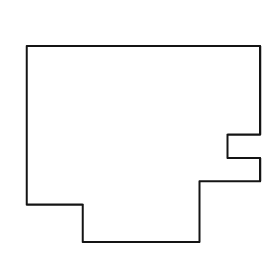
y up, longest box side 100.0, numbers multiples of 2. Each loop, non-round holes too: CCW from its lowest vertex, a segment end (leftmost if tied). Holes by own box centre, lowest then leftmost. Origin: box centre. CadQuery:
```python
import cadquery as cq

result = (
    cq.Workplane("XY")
    .moveTo(-26.0, -42.0)
    .lineTo(24.0, -42.0)
    .lineTo(24.0, -16.0)
    .lineTo(50.0, -16.0)
    .lineTo(50.0, -6.0)
    .lineTo(36.0, -6.0)
    .lineTo(36.0, 4.0)
    .lineTo(50.0, 4.0)
    .lineTo(50.0, 42.0)
    .lineTo(-50.0, 42.0)
    .lineTo(-50.0, -26.0)
    .lineTo(-26.0, -26.0)
    .close()
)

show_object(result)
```